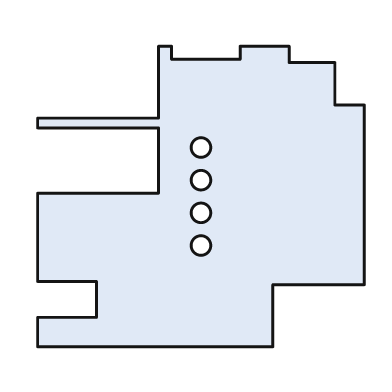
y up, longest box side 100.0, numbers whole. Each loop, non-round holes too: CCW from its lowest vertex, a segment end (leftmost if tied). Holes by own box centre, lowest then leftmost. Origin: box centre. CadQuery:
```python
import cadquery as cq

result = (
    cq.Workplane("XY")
    .moveTo(-50.0, -46.0)
    .lineTo(22.0, -46.0)
    .lineTo(22.0, -27.0)
    .lineTo(50.0, -27.0)
    .lineTo(50.0, 28.0)
    .lineTo(41.0, 28.0)
    .lineTo(41.0, 41.0)
    .lineTo(27.0, 41.0)
    .lineTo(27.0, 46.0)
    .lineTo(12.0, 46.0)
    .lineTo(12.0, 42.0)
    .lineTo(-9.0, 42.0)
    .lineTo(-9.0, 46.0)
    .lineTo(-13.0, 46.0)
    .lineTo(-13.0, 24.0)
    .lineTo(-50.0, 24.0)
    .lineTo(-50.0, 21.0)
    .lineTo(-13.0, 21.0)
    .lineTo(-13.0, 1.0)
    .lineTo(-50.0, 1.0)
    .lineTo(-50.0, -26.0)
    .lineTo(-32.0, -26.0)
    .lineTo(-32.0, -37.0)
    .lineTo(-50.0, -37.0)
    .close()
    .moveTo(0.0, -15.0)
    .circle(3.0)
    .moveTo(0.0, -5.0)
    .circle(3.0)
    .moveTo(0.0, 5.0)
    .circle(3.0)
    .moveTo(0.0, 15.0)
    .circle(3.0)
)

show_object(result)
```